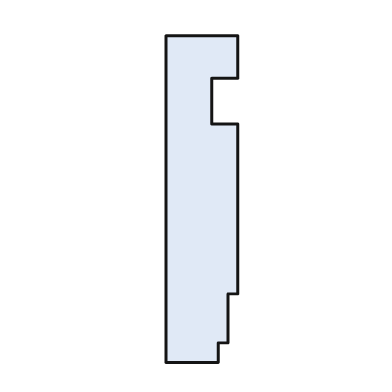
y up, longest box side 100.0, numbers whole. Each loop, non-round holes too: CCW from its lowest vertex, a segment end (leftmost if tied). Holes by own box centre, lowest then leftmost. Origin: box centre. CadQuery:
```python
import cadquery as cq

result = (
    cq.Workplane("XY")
    .moveTo(-11.0, -50.0)
    .lineTo(5.0, -50.0)
    .lineTo(5.0, -44.0)
    .lineTo(8.0, -44.0)
    .lineTo(8.0, -29.0)
    .lineTo(11.0, -29.0)
    .lineTo(11.0, 23.0)
    .lineTo(3.0, 23.0)
    .lineTo(3.0, 37.0)
    .lineTo(11.0, 37.0)
    .lineTo(11.0, 50.0)
    .lineTo(-11.0, 50.0)
    .close()
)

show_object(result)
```